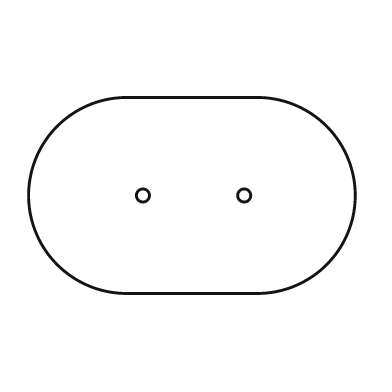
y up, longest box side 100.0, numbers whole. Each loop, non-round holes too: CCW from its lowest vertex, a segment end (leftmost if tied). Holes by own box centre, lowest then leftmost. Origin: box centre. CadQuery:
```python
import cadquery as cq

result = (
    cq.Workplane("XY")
    .moveTo(-20.0, -30.0)
    .lineTo(20.0, -30.0)
    .threePointArc((50.0, 0.0), (20.0, 30.0))
    .lineTo(-20.0, 30.0)
    .threePointArc((-50.0, 0.0), (-20.0, -30.0))
    .close()
    .moveTo(-15.0, 0.0)
    .circle(2.0)
    .moveTo(16.0, 0.0)
    .circle(2.0)
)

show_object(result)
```